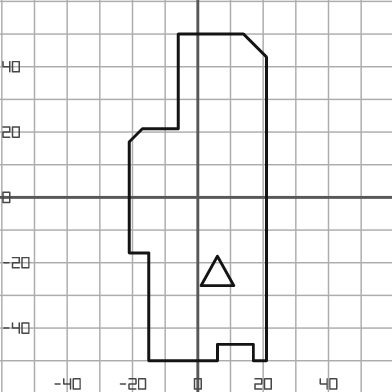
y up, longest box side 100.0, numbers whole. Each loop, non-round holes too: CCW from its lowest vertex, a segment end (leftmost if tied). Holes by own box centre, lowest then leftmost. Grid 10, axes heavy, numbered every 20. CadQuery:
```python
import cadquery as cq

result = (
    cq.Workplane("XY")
    .moveTo(-15.0, -50.0)
    .lineTo(6.0, -50.0)
    .lineTo(6.0, -45.0)
    .lineTo(17.0, -45.0)
    .lineTo(17.0, -50.0)
    .lineTo(21.0, -50.0)
    .lineTo(21.0, 43.0)
    .lineTo(14.0, 50.0)
    .lineTo(-6.0, 50.0)
    .lineTo(-6.0, 21.0)
    .lineTo(-17.0, 21.0)
    .lineTo(-21.0, 17.0)
    .lineTo(-21.0, -17.0)
    .lineTo(-15.0, -17.0)
    .close()
    .moveTo(1.0, -27.0)
    .lineTo(11.0, -27.0)
    .lineTo(6.0, -18.0)
    .close()
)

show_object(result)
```